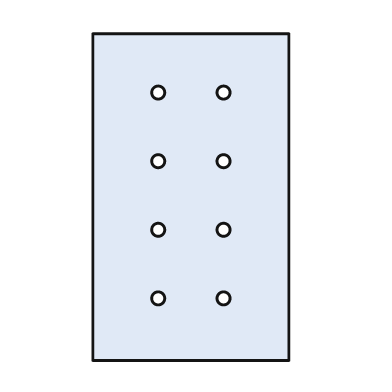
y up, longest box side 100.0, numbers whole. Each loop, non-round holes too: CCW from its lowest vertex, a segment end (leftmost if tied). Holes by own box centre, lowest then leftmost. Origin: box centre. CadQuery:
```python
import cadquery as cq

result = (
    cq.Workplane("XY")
    .moveTo(-30.0, -50.0)
    .lineTo(30.0, -50.0)
    .lineTo(30.0, 50.0)
    .lineTo(-30.0, 50.0)
    .close()
    .moveTo(-10.0, -31.0)
    .circle(2.0)
    .moveTo(10.0, -31.0)
    .circle(2.0)
    .moveTo(-10.0, -10.0)
    .circle(2.0)
    .moveTo(10.0, -10.0)
    .circle(2.0)
    .moveTo(-10.0, 11.0)
    .circle(2.0)
    .moveTo(10.0, 11.0)
    .circle(2.0)
    .moveTo(-10.0, 32.0)
    .circle(2.0)
    .moveTo(10.0, 32.0)
    .circle(2.0)
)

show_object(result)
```